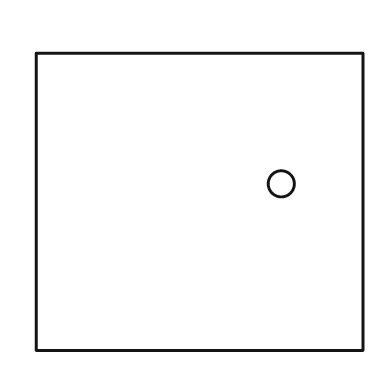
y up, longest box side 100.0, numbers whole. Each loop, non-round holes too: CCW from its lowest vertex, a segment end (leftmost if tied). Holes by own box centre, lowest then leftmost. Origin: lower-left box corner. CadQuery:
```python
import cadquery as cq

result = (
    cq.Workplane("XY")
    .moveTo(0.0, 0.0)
    .lineTo(100.0, 0.0)
    .lineTo(100.0, 91.0)
    .lineTo(0.0, 91.0)
    .close()
    .moveTo(75.0, 51.0)
    .circle(4.0)
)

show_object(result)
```